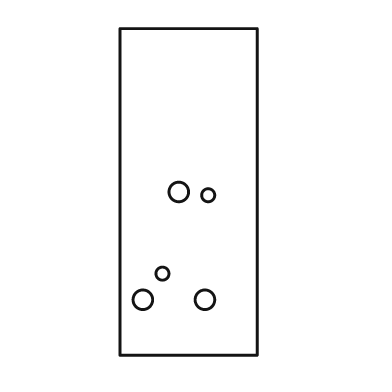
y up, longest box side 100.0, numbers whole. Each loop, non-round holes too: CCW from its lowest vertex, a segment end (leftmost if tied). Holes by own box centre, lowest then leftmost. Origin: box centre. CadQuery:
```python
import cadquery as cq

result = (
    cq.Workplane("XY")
    .moveTo(-21.0, -50.0)
    .lineTo(21.0, -50.0)
    .lineTo(21.0, 50.0)
    .lineTo(-21.0, 50.0)
    .close()
    .moveTo(-14.0, -33.0)
    .circle(3.0)
    .moveTo(5.0, -33.0)
    .circle(3.0)
    .moveTo(-8.0, -25.0)
    .circle(2.0)
    .moveTo(6.0, -1.0)
    .circle(2.0)
    .moveTo(-3.0, 0.0)
    .circle(3.0)
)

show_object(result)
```